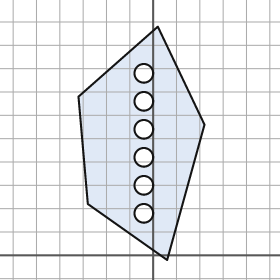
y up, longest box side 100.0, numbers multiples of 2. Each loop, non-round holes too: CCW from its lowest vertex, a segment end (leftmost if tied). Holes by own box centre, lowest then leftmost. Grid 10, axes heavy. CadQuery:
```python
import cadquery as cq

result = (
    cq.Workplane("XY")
    .moveTo(6.0, -2.0)
    .lineTo(22.0, 56.0)
    .lineTo(2.0, 98.0)
    .lineTo(-32.0, 68.0)
    .lineTo(-28.0, 22.0)
    .close()
    .moveTo(-4.0, 18.0)
    .circle(4.0)
    .moveTo(-4.0, 30.0)
    .circle(4.0)
    .moveTo(-4.0, 42.0)
    .circle(4.0)
    .moveTo(-4.0, 54.0)
    .circle(4.0)
    .moveTo(-4.0, 66.0)
    .circle(4.0)
    .moveTo(-4.0, 78.0)
    .circle(4.0)
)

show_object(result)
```